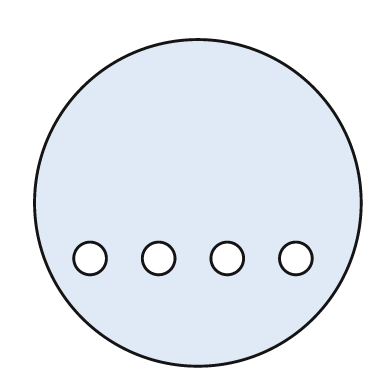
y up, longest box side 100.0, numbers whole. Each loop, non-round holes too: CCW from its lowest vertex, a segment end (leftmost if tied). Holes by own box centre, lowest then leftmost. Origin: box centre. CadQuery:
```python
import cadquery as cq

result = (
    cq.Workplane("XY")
    .moveTo(0.0, 0.0)
    .circle(50.0)
    .moveTo(-33.0, -17.0)
    .circle(5.0)
    .moveTo(-12.0, -17.0)
    .circle(5.0)
    .moveTo(9.0, -17.0)
    .circle(5.0)
    .moveTo(30.0, -17.0)
    .circle(5.0)
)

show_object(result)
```